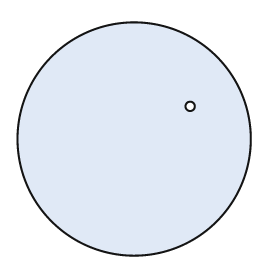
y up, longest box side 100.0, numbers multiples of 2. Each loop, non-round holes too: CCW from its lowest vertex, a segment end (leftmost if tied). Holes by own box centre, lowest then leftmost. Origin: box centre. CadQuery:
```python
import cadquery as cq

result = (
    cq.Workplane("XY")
    .moveTo(0.0, 0.0)
    .circle(50.0)
    .moveTo(24.0, 14.0)
    .circle(2.0)
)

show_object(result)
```